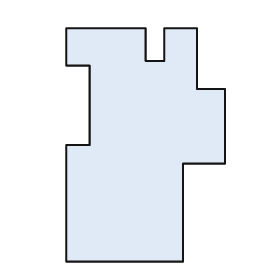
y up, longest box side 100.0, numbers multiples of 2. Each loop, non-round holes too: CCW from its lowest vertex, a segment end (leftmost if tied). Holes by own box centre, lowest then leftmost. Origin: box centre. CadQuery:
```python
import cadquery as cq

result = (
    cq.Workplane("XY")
    .moveTo(-34.0, -50.0)
    .lineTo(16.0, -50.0)
    .lineTo(16.0, -8.0)
    .lineTo(34.0, -8.0)
    .lineTo(34.0, 24.0)
    .lineTo(22.0, 24.0)
    .lineTo(22.0, 50.0)
    .lineTo(8.0, 50.0)
    .lineTo(8.0, 36.0)
    .lineTo(0.0, 36.0)
    .lineTo(0.0, 50.0)
    .lineTo(-34.0, 50.0)
    .lineTo(-34.0, 34.0)
    .lineTo(-24.0, 34.0)
    .lineTo(-24.0, 0.0)
    .lineTo(-34.0, 0.0)
    .close()
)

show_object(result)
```